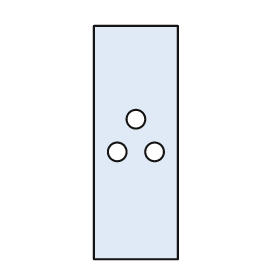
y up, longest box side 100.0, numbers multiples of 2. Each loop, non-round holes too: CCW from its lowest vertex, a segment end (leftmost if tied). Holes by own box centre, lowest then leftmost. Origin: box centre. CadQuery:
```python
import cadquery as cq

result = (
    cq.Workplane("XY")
    .moveTo(-18.0, -50.0)
    .lineTo(18.0, -50.0)
    .lineTo(18.0, 50.0)
    .lineTo(-18.0, 50.0)
    .close()
    .moveTo(-8.0, -4.0)
    .circle(4.0)
    .moveTo(8.0, -4.0)
    .circle(4.0)
    .moveTo(0.0, 10.0)
    .circle(4.0)
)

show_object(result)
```